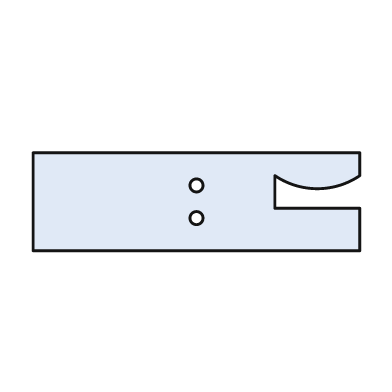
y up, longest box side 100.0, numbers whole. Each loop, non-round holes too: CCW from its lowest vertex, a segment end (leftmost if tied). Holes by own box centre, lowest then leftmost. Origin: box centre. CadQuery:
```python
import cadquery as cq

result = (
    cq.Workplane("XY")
    .moveTo(-50.0, -15.0)
    .lineTo(50.0, -15.0)
    .lineTo(50.0, -2.0)
    .lineTo(24.0, -2.0)
    .lineTo(24.0, 8.0)
    .threePointArc((37.0, 4.0), (50.0, 8.0))
    .lineTo(50.0, 15.0)
    .lineTo(-50.0, 15.0)
    .close()
    .moveTo(0.0, -5.0)
    .circle(2.0)
    .moveTo(0.0, 5.0)
    .circle(2.0)
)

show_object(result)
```